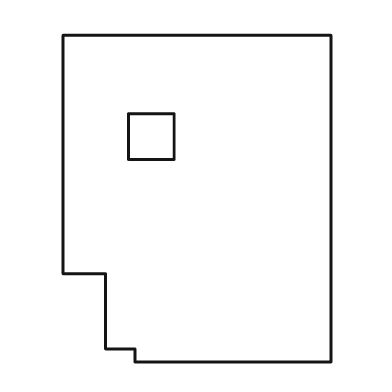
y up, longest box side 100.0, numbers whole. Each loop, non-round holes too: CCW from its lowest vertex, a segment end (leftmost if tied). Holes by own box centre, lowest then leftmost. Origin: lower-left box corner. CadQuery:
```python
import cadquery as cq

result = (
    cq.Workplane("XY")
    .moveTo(22.0, 0.0)
    .lineTo(82.0, 0.0)
    .lineTo(82.0, 100.0)
    .lineTo(0.0, 100.0)
    .lineTo(0.0, 27.0)
    .lineTo(13.0, 27.0)
    .lineTo(13.0, 4.0)
    .lineTo(22.0, 4.0)
    .close()
    .moveTo(20.0, 62.0)
    .lineTo(34.0, 62.0)
    .lineTo(34.0, 76.0)
    .lineTo(20.0, 76.0)
    .close()
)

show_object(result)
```